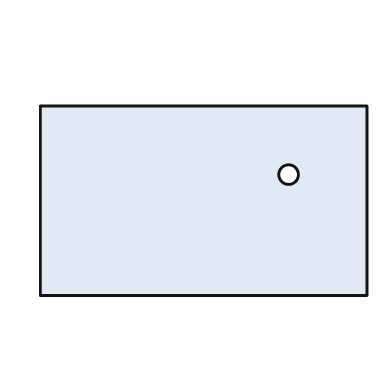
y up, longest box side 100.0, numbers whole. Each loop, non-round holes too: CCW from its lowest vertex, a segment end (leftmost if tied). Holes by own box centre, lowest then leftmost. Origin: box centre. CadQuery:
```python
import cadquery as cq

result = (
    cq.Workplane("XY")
    .moveTo(-50.0, -29.0)
    .lineTo(50.0, -29.0)
    .lineTo(50.0, 29.0)
    .lineTo(-50.0, 29.0)
    .close()
    .moveTo(26.0, 8.0)
    .circle(3.0)
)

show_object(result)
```